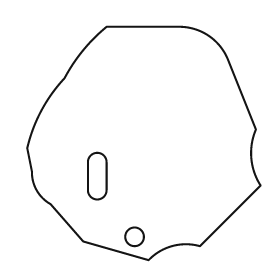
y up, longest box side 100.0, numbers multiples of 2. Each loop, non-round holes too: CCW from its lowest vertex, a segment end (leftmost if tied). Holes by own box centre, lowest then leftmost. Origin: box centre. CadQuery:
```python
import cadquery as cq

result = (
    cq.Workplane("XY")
    .moveTo(2.0, -50.0)
    .threePointArc((12.0, -44.0), (24.0, -44.0))
    .lineTo(50.0, -18.0)
    .threePointArc((46.0, -6.0), (48.0, 6.0))
    .lineTo(36.0, 36.0)
    .threePointArc((28.0, 46.0), (16.0, 50.0))
    .lineTo(-16.0, 50.0)
    .threePointArc((-26.0, 40.0), (-34.0, 28.0))
    .threePointArc((-44.0, 14.0), (-50.0, -2.0))
    .lineTo(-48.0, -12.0)
    .threePointArc((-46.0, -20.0), (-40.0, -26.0))
    .lineTo(-26.0, -42.0)
    .close()
    .moveTo(-4.0, -40.0)
    .circle(4.0)
    .moveTo(-24.0, -20.0)
    .threePointArc((-20.0, -24.0), (-16.0, -20.0))
    .lineTo(-16.0, -8.0)
    .threePointArc((-20.0, -4.0), (-24.0, -8.0))
    .close()
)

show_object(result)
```